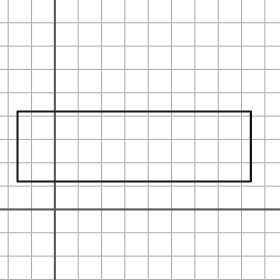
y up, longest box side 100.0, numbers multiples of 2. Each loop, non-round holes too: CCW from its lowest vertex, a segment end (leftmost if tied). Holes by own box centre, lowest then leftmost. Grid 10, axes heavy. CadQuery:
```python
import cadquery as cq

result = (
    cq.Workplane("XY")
    .moveTo(-16.0, 12.0)
    .lineTo(84.0, 12.0)
    .lineTo(84.0, 42.0)
    .lineTo(-16.0, 42.0)
    .close()
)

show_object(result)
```